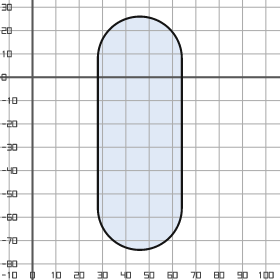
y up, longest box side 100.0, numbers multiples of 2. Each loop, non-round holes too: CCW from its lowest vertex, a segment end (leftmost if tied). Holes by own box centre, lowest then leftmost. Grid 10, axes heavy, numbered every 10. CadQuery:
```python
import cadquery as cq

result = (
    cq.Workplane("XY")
    .moveTo(28.0, -56.0)
    .threePointArc((46.0, -74.0), (64.0, -56.0))
    .lineTo(64.0, 8.0)
    .threePointArc((46.0, 26.0), (28.0, 8.0))
    .close()
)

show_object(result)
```